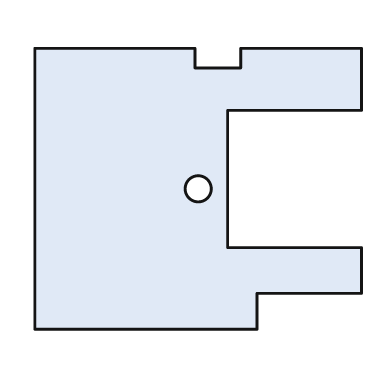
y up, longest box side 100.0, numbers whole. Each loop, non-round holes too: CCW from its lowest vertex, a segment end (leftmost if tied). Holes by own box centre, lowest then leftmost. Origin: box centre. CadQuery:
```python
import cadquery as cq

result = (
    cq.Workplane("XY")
    .moveTo(-50.0, -43.0)
    .lineTo(18.0, -43.0)
    .lineTo(18.0, -32.0)
    .lineTo(50.0, -32.0)
    .lineTo(50.0, -18.0)
    .lineTo(9.0, -18.0)
    .lineTo(9.0, 24.0)
    .lineTo(50.0, 24.0)
    .lineTo(50.0, 43.0)
    .lineTo(13.0, 43.0)
    .lineTo(13.0, 37.0)
    .lineTo(-1.0, 37.0)
    .lineTo(-1.0, 43.0)
    .lineTo(-50.0, 43.0)
    .close()
    .moveTo(0.0, 0.0)
    .circle(4.0)
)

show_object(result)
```